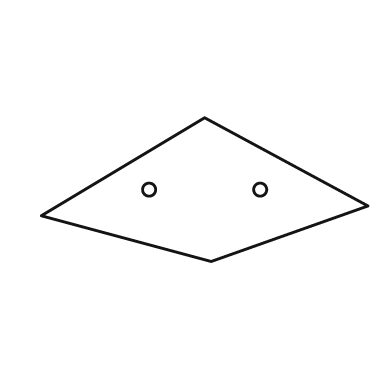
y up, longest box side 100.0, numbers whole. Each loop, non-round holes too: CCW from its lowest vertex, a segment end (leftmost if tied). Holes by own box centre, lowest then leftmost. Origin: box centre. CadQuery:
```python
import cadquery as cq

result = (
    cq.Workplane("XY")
    .moveTo(2.0, -22.0)
    .lineTo(50.0, -5.0)
    .lineTo(0.0, 22.0)
    .lineTo(-50.0, -8.0)
    .close()
    .moveTo(-17.0, 0.0)
    .circle(2.0)
    .moveTo(17.0, 0.0)
    .circle(2.0)
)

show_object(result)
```